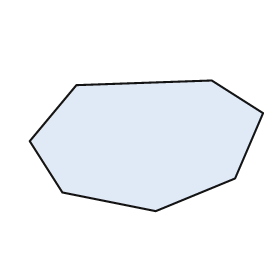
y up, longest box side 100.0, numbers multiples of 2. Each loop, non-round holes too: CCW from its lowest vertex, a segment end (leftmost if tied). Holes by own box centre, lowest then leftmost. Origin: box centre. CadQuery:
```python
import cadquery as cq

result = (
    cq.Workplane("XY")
    .moveTo(4.0, -28.0)
    .lineTo(38.0, -14.0)
    .lineTo(50.0, 14.0)
    .lineTo(28.0, 28.0)
    .lineTo(-30.0, 26.0)
    .lineTo(-50.0, 2.0)
    .lineTo(-36.0, -20.0)
    .close()
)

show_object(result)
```